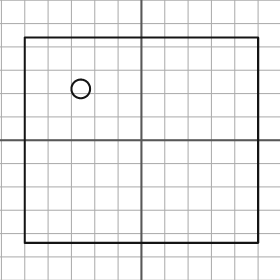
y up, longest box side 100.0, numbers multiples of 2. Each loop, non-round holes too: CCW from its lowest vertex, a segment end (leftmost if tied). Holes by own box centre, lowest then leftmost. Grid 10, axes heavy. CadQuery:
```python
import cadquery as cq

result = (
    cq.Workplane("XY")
    .moveTo(-50.0, -44.0)
    .lineTo(50.0, -44.0)
    .lineTo(50.0, 44.0)
    .lineTo(-50.0, 44.0)
    .close()
    .moveTo(-26.0, 22.0)
    .circle(4.0)
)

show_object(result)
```